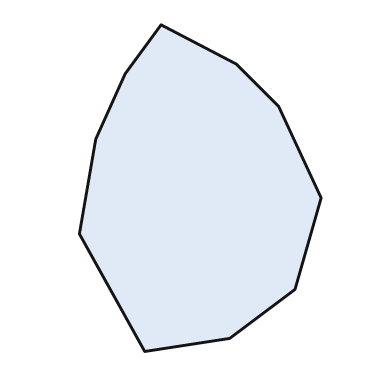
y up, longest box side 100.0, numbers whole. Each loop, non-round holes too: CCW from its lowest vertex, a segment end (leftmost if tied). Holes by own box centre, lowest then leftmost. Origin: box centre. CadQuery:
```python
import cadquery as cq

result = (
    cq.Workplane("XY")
    .moveTo(-17.0, -50.0)
    .lineTo(9.0, -46.0)
    .lineTo(29.0, -31.0)
    .lineTo(37.0, -3.0)
    .lineTo(24.0, 25.0)
    .lineTo(11.0, 38.0)
    .lineTo(-12.0, 50.0)
    .lineTo(-23.0, 35.0)
    .lineTo(-32.0, 15.0)
    .lineTo(-37.0, -14.0)
    .close()
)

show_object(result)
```